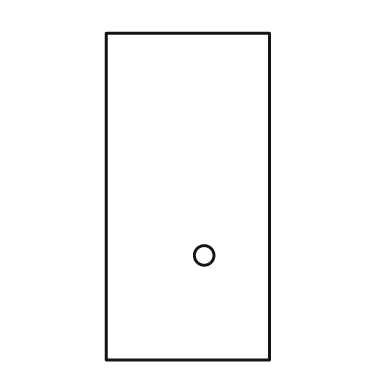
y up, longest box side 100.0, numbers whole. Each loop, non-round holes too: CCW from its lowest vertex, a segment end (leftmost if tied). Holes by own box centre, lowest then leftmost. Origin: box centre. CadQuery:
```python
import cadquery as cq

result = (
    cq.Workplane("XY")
    .moveTo(-25.0, -50.0)
    .lineTo(25.0, -50.0)
    .lineTo(25.0, 50.0)
    .lineTo(-25.0, 50.0)
    .close()
    .moveTo(5.0, -18.0)
    .circle(3.0)
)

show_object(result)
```